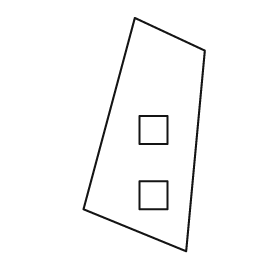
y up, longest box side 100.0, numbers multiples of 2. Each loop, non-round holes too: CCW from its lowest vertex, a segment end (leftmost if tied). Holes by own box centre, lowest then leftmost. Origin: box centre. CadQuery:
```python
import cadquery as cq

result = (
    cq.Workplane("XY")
    .moveTo(18.0, -50.0)
    .lineTo(26.0, 36.0)
    .lineTo(-4.0, 50.0)
    .lineTo(-26.0, -32.0)
    .close()
    .moveTo(-2.0, -32.0)
    .lineTo(10.0, -32.0)
    .lineTo(10.0, -20.0)
    .lineTo(-2.0, -20.0)
    .close()
    .moveTo(-2.0, -4.0)
    .lineTo(10.0, -4.0)
    .lineTo(10.0, 8.0)
    .lineTo(-2.0, 8.0)
    .close()
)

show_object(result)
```